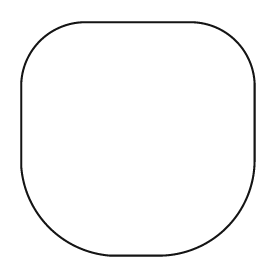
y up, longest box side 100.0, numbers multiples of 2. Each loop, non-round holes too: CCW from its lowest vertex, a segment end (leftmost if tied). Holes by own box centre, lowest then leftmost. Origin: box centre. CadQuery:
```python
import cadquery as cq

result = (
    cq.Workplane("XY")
    .moveTo(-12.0, -50.0)
    .lineTo(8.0, -50.0)
    .threePointArc((38.0, -38.0), (50.0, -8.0))
    .lineTo(50.0, 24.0)
    .threePointArc((42.0, 42.0), (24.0, 50.0))
    .lineTo(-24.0, 50.0)
    .threePointArc((-42.0, 42.0), (-50.0, 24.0))
    .lineTo(-50.0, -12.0)
    .threePointArc((-38.0, -38.0), (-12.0, -50.0))
    .close()
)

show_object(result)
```